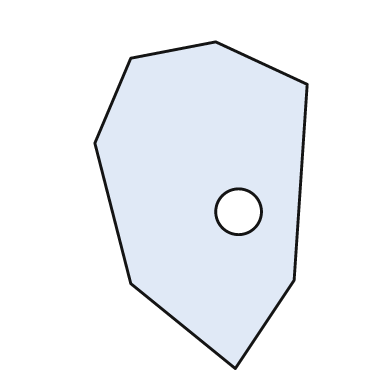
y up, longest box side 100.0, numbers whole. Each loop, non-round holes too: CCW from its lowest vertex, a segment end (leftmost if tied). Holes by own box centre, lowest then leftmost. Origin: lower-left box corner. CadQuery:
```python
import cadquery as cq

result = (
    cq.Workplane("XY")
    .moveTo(43.0, 0.0)
    .lineTo(61.0, 27.0)
    .lineTo(65.0, 87.0)
    .lineTo(37.0, 100.0)
    .lineTo(11.0, 95.0)
    .lineTo(0.0, 69.0)
    .lineTo(11.0, 26.0)
    .close()
    .moveTo(44.0, 48.0)
    .circle(7.0)
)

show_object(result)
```